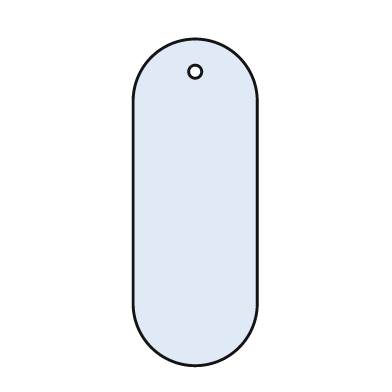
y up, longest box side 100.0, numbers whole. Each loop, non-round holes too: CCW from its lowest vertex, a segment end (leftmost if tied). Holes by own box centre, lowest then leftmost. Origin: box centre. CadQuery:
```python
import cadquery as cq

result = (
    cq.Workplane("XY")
    .moveTo(-19.0, -31.0)
    .threePointArc((0.0, -50.0), (19.0, -31.0))
    .lineTo(19.0, 31.0)
    .threePointArc((0.0, 50.0), (-19.0, 31.0))
    .close()
    .moveTo(0.0, 40.0)
    .circle(2.0)
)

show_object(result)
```